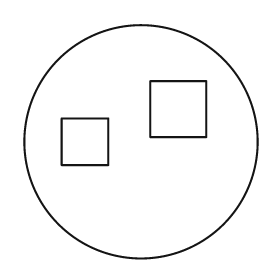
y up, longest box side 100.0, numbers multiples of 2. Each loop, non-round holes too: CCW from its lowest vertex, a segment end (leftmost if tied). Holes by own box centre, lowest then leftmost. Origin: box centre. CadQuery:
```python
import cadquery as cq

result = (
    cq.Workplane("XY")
    .moveTo(0.0, 0.0)
    .circle(50.0)
    .moveTo(-34.0, -10.0)
    .lineTo(-14.0, -10.0)
    .lineTo(-14.0, 10.0)
    .lineTo(-34.0, 10.0)
    .close()
    .moveTo(4.0, 2.0)
    .lineTo(28.0, 2.0)
    .lineTo(28.0, 26.0)
    .lineTo(4.0, 26.0)
    .close()
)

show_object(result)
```